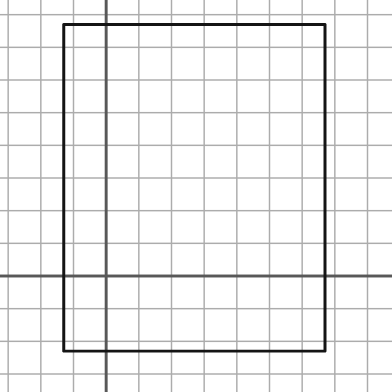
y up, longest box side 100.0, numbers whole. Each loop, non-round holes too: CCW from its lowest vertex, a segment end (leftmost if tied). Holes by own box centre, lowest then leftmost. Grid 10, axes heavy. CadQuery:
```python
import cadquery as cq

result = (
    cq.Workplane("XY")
    .moveTo(-13.0, -23.0)
    .lineTo(67.0, -23.0)
    .lineTo(67.0, 77.0)
    .lineTo(-13.0, 77.0)
    .close()
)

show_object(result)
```